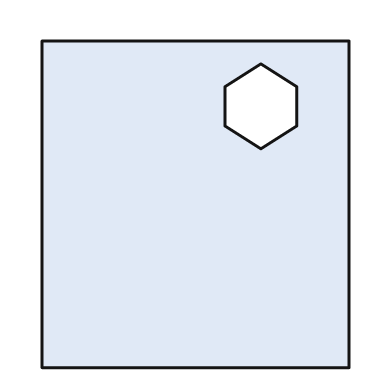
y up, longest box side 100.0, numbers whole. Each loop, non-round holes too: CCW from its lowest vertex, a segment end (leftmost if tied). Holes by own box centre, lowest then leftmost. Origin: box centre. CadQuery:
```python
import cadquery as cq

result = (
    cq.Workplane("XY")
    .moveTo(-47.0, -50.0)
    .lineTo(47.0, -50.0)
    .lineTo(47.0, 50.0)
    .lineTo(-47.0, 50.0)
    .close()
    .moveTo(20.0, 17.0)
    .lineTo(31.0, 24.0)
    .lineTo(31.0, 36.0)
    .lineTo(20.0, 43.0)
    .lineTo(9.0, 36.0)
    .lineTo(9.0, 24.0)
    .close()
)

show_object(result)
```